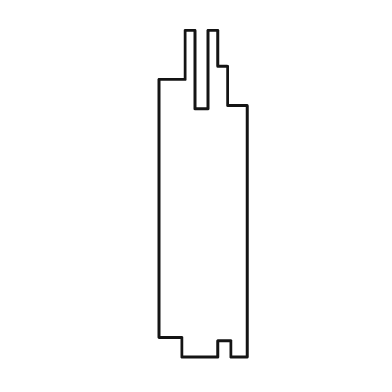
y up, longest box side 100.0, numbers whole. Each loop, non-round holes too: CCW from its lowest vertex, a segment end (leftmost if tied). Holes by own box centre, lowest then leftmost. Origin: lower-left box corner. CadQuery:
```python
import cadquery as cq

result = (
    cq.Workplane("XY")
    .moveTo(7.0, 0.0)
    .lineTo(18.0, 0.0)
    .lineTo(18.0, 5.0)
    .lineTo(22.0, 5.0)
    .lineTo(22.0, 0.0)
    .lineTo(27.0, 0.0)
    .lineTo(27.0, 77.0)
    .lineTo(21.0, 77.0)
    .lineTo(21.0, 89.0)
    .lineTo(18.0, 89.0)
    .lineTo(18.0, 100.0)
    .lineTo(15.0, 100.0)
    .lineTo(15.0, 76.0)
    .lineTo(11.0, 76.0)
    .lineTo(11.0, 100.0)
    .lineTo(8.0, 100.0)
    .lineTo(8.0, 85.0)
    .lineTo(0.0, 85.0)
    .lineTo(0.0, 6.0)
    .lineTo(7.0, 6.0)
    .close()
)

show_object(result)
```